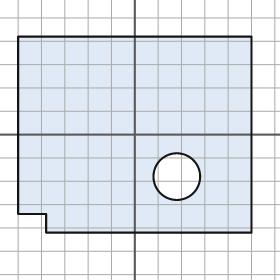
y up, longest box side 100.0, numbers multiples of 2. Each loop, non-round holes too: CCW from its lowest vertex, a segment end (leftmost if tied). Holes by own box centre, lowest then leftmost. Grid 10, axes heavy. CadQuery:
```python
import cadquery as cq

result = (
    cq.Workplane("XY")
    .moveTo(-38.0, -42.0)
    .lineTo(50.0, -42.0)
    .lineTo(50.0, 42.0)
    .lineTo(-50.0, 42.0)
    .lineTo(-50.0, -34.0)
    .lineTo(-38.0, -34.0)
    .close()
    .moveTo(18.0, -18.0)
    .circle(10.0)
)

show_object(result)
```